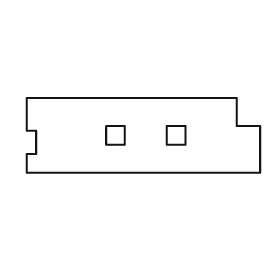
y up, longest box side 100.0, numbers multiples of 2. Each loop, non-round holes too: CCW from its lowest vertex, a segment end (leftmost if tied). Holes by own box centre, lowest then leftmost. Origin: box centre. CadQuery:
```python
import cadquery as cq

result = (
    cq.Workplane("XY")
    .moveTo(-50.0, -16.0)
    .lineTo(50.0, -16.0)
    .lineTo(50.0, 4.0)
    .lineTo(40.0, 4.0)
    .lineTo(40.0, 16.0)
    .lineTo(-50.0, 16.0)
    .lineTo(-50.0, 2.0)
    .lineTo(-46.0, 2.0)
    .lineTo(-46.0, -8.0)
    .lineTo(-50.0, -8.0)
    .close()
    .moveTo(-16.0, -4.0)
    .lineTo(-8.0, -4.0)
    .lineTo(-8.0, 4.0)
    .lineTo(-16.0, 4.0)
    .close()
    .moveTo(10.0, -4.0)
    .lineTo(18.0, -4.0)
    .lineTo(18.0, 4.0)
    .lineTo(10.0, 4.0)
    .close()
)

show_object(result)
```